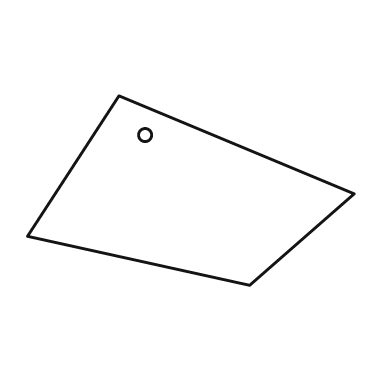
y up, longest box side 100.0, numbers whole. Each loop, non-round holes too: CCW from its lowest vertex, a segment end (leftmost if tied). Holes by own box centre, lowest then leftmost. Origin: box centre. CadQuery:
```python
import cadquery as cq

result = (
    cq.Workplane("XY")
    .moveTo(18.0, -29.0)
    .lineTo(50.0, -1.0)
    .lineTo(-22.0, 29.0)
    .lineTo(-50.0, -14.0)
    .close()
    .moveTo(-14.0, 17.0)
    .circle(2.0)
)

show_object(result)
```